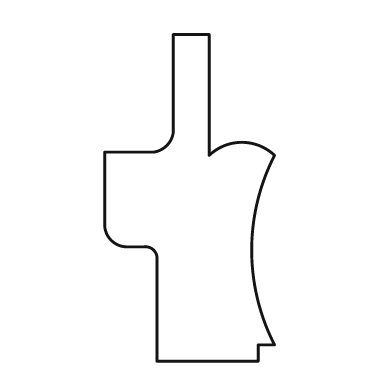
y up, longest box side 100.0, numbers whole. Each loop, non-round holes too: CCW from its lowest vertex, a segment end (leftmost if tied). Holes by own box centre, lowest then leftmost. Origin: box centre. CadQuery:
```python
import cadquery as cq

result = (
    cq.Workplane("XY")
    .moveTo(-10.0, -50.0)
    .lineTo(21.0, -50.0)
    .lineTo(21.0, -45.0)
    .lineTo(26.0, -45.0)
    .threePointArc((19.0, -16.0), (26.0, 13.0))
    .threePointArc((16.0, 17.0), (6.0, 13.0))
    .lineTo(6.0, 50.0)
    .lineTo(-5.0, 50.0)
    .lineTo(-5.0, 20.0)
    .threePointArc((-7.0, 16.0), (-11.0, 14.0))
    .lineTo(-26.0, 14.0)
    .lineTo(-26.0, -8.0)
    .threePointArc((-24.0, -13.0), (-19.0, -15.0))
    .lineTo(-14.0, -15.0)
    .threePointArc((-11.0, -16.0), (-10.0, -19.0))
    .close()
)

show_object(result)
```